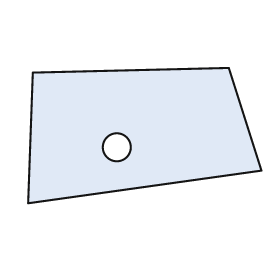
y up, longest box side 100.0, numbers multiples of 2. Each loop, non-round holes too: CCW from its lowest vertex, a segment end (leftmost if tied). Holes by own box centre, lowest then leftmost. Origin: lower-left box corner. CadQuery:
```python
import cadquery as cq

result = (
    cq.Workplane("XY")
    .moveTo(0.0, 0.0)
    .lineTo(100.0, 14.0)
    .lineTo(86.0, 58.0)
    .lineTo(2.0, 56.0)
    .close()
    .moveTo(38.0, 24.0)
    .circle(6.0)
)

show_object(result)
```